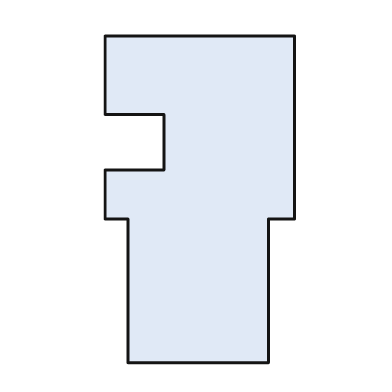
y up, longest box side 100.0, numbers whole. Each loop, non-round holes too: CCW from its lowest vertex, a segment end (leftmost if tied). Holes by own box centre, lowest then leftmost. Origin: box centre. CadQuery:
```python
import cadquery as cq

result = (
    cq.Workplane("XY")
    .moveTo(-22.0, -50.0)
    .lineTo(21.0, -50.0)
    .lineTo(21.0, -6.0)
    .lineTo(29.0, -6.0)
    .lineTo(29.0, 50.0)
    .lineTo(-29.0, 50.0)
    .lineTo(-29.0, 26.0)
    .lineTo(-11.0, 26.0)
    .lineTo(-11.0, 9.0)
    .lineTo(-29.0, 9.0)
    .lineTo(-29.0, -6.0)
    .lineTo(-22.0, -6.0)
    .close()
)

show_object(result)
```